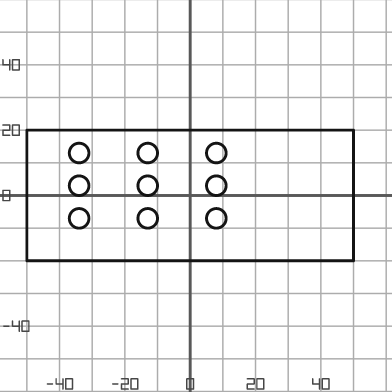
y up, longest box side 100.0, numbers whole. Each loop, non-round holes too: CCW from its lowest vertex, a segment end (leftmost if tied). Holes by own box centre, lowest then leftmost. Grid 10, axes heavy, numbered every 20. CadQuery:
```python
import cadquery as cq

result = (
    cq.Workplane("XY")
    .moveTo(-50.0, -20.0)
    .lineTo(50.0, -20.0)
    .lineTo(50.0, 20.0)
    .lineTo(-50.0, 20.0)
    .close()
    .moveTo(-34.0, -7.0)
    .circle(3.0)
    .moveTo(-13.0, -7.0)
    .circle(3.0)
    .moveTo(8.0, -7.0)
    .circle(3.0)
    .moveTo(-34.0, 3.0)
    .circle(3.0)
    .moveTo(-13.0, 3.0)
    .circle(3.0)
    .moveTo(8.0, 3.0)
    .circle(3.0)
    .moveTo(-34.0, 13.0)
    .circle(3.0)
    .moveTo(-13.0, 13.0)
    .circle(3.0)
    .moveTo(8.0, 13.0)
    .circle(3.0)
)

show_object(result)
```